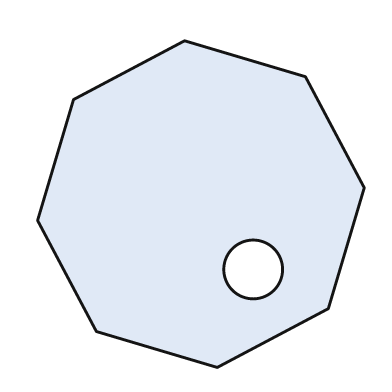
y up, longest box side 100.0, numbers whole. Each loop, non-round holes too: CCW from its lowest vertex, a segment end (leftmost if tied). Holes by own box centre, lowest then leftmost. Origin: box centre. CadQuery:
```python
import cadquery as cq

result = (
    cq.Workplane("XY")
    .moveTo(5.0, -50.0)
    .lineTo(39.0, -32.0)
    .lineTo(50.0, 5.0)
    .lineTo(32.0, 39.0)
    .lineTo(-5.0, 50.0)
    .lineTo(-39.0, 32.0)
    .lineTo(-50.0, -5.0)
    .lineTo(-32.0, -39.0)
    .close()
    .moveTo(16.0, -20.0)
    .circle(9.0)
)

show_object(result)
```